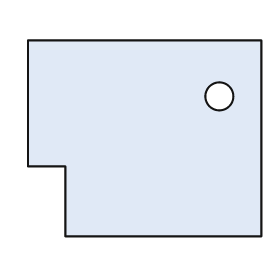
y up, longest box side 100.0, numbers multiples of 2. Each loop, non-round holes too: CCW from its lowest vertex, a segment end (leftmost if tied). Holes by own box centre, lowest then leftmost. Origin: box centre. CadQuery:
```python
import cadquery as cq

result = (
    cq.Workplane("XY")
    .moveTo(-34.0, -42.0)
    .lineTo(50.0, -42.0)
    .lineTo(50.0, 42.0)
    .lineTo(-50.0, 42.0)
    .lineTo(-50.0, -12.0)
    .lineTo(-34.0, -12.0)
    .close()
    .moveTo(32.0, 18.0)
    .circle(6.0)
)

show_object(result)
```